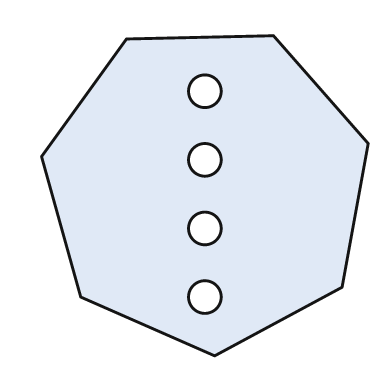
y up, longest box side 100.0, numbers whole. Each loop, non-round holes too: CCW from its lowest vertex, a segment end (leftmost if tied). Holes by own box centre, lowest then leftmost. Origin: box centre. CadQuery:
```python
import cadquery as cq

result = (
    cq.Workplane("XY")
    .moveTo(3.0, -49.0)
    .lineTo(42.0, -28.0)
    .lineTo(50.0, 16.0)
    .lineTo(21.0, 49.0)
    .lineTo(-24.0, 48.0)
    .lineTo(-50.0, 12.0)
    .lineTo(-38.0, -31.0)
    .close()
    .moveTo(0.0, -31.0)
    .circle(5.0)
    .moveTo(0.0, -10.0)
    .circle(5.0)
    .moveTo(0.0, 11.0)
    .circle(5.0)
    .moveTo(0.0, 32.0)
    .circle(5.0)
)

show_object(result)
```